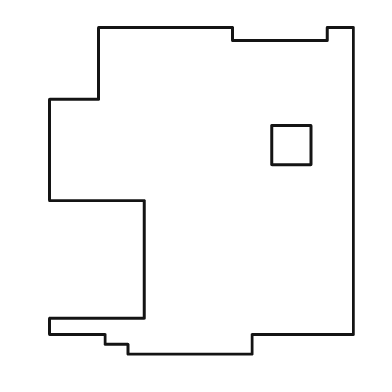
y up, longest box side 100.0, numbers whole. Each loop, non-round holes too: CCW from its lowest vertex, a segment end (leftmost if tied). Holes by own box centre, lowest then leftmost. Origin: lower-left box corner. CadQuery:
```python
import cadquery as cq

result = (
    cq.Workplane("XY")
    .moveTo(24.0, 0.0)
    .lineTo(62.0, 0.0)
    .lineTo(62.0, 6.0)
    .lineTo(93.0, 6.0)
    .lineTo(93.0, 100.0)
    .lineTo(85.0, 100.0)
    .lineTo(85.0, 96.0)
    .lineTo(56.0, 96.0)
    .lineTo(56.0, 100.0)
    .lineTo(15.0, 100.0)
    .lineTo(15.0, 78.0)
    .lineTo(0.0, 78.0)
    .lineTo(0.0, 47.0)
    .lineTo(29.0, 47.0)
    .lineTo(29.0, 11.0)
    .lineTo(0.0, 11.0)
    .lineTo(0.0, 6.0)
    .lineTo(17.0, 6.0)
    .lineTo(17.0, 3.0)
    .lineTo(24.0, 3.0)
    .close()
    .moveTo(68.0, 58.0)
    .lineTo(80.0, 58.0)
    .lineTo(80.0, 70.0)
    .lineTo(68.0, 70.0)
    .close()
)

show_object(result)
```